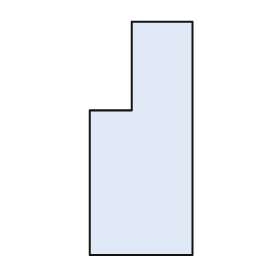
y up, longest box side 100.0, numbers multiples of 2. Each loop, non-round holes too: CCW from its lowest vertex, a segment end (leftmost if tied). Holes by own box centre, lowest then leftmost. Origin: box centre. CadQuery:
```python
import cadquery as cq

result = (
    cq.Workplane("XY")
    .moveTo(-22.0, -50.0)
    .lineTo(22.0, -50.0)
    .lineTo(22.0, 50.0)
    .lineTo(-4.0, 50.0)
    .lineTo(-4.0, 12.0)
    .lineTo(-22.0, 12.0)
    .close()
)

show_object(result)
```